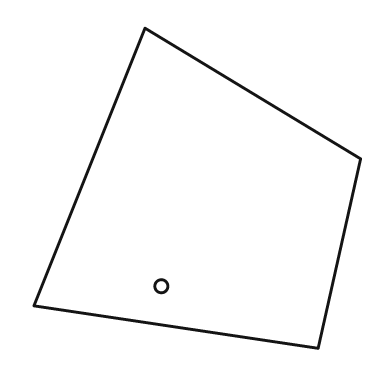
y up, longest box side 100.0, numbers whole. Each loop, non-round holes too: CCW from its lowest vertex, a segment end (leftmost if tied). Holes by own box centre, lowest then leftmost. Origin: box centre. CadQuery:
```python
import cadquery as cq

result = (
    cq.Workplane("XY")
    .moveTo(37.0, -49.0)
    .lineTo(50.0, 9.0)
    .lineTo(-16.0, 49.0)
    .lineTo(-50.0, -36.0)
    .close()
    .moveTo(-11.0, -30.0)
    .circle(2.0)
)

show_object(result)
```